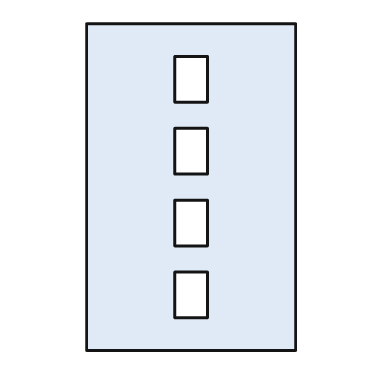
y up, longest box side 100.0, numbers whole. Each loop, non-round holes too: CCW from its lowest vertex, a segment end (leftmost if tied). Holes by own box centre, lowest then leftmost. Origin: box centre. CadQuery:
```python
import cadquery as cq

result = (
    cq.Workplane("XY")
    .moveTo(-32.0, -50.0)
    .lineTo(32.0, -50.0)
    .lineTo(32.0, 50.0)
    .lineTo(-32.0, 50.0)
    .close()
    .moveTo(-5.0, -40.0)
    .lineTo(5.0, -40.0)
    .lineTo(5.0, -26.0)
    .lineTo(-5.0, -26.0)
    .close()
    .moveTo(-5.0, -18.0)
    .lineTo(5.0, -18.0)
    .lineTo(5.0, -4.0)
    .lineTo(-5.0, -4.0)
    .close()
    .moveTo(-5.0, 4.0)
    .lineTo(5.0, 4.0)
    .lineTo(5.0, 18.0)
    .lineTo(-5.0, 18.0)
    .close()
    .moveTo(-5.0, 26.0)
    .lineTo(5.0, 26.0)
    .lineTo(5.0, 40.0)
    .lineTo(-5.0, 40.0)
    .close()
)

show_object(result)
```